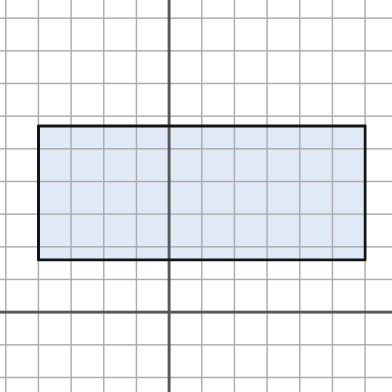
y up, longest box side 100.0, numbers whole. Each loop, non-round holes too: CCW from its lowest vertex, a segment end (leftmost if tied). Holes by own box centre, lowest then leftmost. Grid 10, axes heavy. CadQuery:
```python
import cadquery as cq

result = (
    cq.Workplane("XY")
    .moveTo(-40.0, 16.0)
    .lineTo(60.0, 16.0)
    .lineTo(60.0, 57.0)
    .lineTo(-40.0, 57.0)
    .close()
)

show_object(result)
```